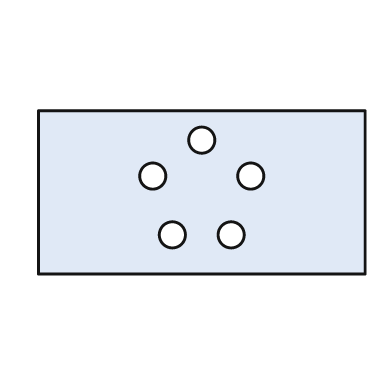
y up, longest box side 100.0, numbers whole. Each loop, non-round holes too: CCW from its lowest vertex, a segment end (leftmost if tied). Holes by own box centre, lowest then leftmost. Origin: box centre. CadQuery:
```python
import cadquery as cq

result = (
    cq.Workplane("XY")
    .moveTo(-50.0, -25.0)
    .lineTo(50.0, -25.0)
    .lineTo(50.0, 25.0)
    .lineTo(-50.0, 25.0)
    .close()
    .moveTo(-9.0, -13.0)
    .circle(4.0)
    .moveTo(9.0, -13.0)
    .circle(4.0)
    .moveTo(-15.0, 5.0)
    .circle(4.0)
    .moveTo(15.0, 5.0)
    .circle(4.0)
    .moveTo(0.0, 16.0)
    .circle(4.0)
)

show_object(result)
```